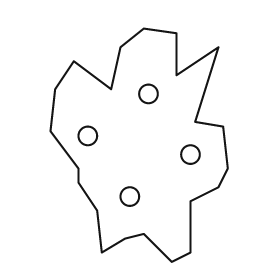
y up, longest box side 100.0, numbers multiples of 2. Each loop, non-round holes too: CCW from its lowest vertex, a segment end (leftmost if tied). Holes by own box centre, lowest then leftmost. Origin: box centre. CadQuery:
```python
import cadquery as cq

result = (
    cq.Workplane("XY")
    .moveTo(14.0, -50.0)
    .lineTo(22.0, -46.0)
    .lineTo(22.0, -24.0)
    .lineTo(34.0, -18.0)
    .lineTo(38.0, -10.0)
    .lineTo(36.0, 8.0)
    .lineTo(24.0, 10.0)
    .lineTo(34.0, 42.0)
    .lineTo(16.0, 30.0)
    .lineTo(16.0, 48.0)
    .lineTo(2.0, 50.0)
    .lineTo(-8.0, 42.0)
    .lineTo(-12.0, 24.0)
    .lineTo(-28.0, 36.0)
    .lineTo(-36.0, 24.0)
    .lineTo(-38.0, 6.0)
    .lineTo(-26.0, -10.0)
    .lineTo(-26.0, -16.0)
    .lineTo(-18.0, -28.0)
    .lineTo(-16.0, -46.0)
    .lineTo(-6.0, -40.0)
    .lineTo(2.0, -38.0)
    .close()
    .moveTo(-4.0, -22.0)
    .circle(4.0)
    .moveTo(22.0, -4.0)
    .circle(4.0)
    .moveTo(-22.0, 4.0)
    .circle(4.0)
    .moveTo(4.0, 22.0)
    .circle(4.0)
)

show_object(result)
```